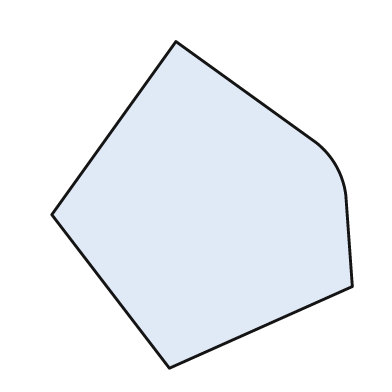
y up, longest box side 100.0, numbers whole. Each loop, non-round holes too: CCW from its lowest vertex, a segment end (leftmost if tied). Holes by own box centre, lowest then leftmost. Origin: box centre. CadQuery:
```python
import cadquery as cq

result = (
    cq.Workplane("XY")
    .moveTo(-10.0, -50.0)
    .lineTo(46.0, -25.0)
    .lineTo(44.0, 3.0)
    .threePointArc((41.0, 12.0), (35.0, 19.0))
    .lineTo(-8.0, 50.0)
    .lineTo(-46.0, -3.0)
    .close()
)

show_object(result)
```